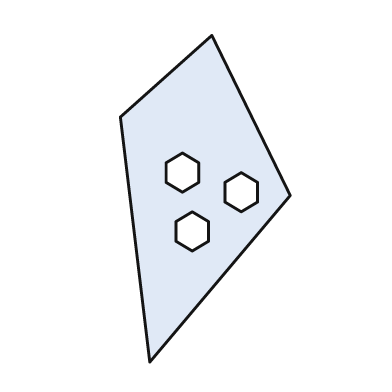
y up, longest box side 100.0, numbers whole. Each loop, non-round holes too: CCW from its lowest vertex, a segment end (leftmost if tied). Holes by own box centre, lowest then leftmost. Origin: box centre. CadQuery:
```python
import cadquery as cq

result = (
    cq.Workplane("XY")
    .moveTo(-17.0, -50.0)
    .lineTo(26.0, 1.0)
    .lineTo(2.0, 50.0)
    .lineTo(-26.0, 25.0)
    .close()
    .moveTo(-4.0, -16.0)
    .lineTo(1.0, -13.0)
    .lineTo(1.0, -7.0)
    .lineTo(-4.0, -4.0)
    .lineTo(-9.0, -7.0)
    .lineTo(-9.0, -13.0)
    .close()
    .moveTo(11.0, -4.0)
    .lineTo(16.0, -1.0)
    .lineTo(16.0, 5.0)
    .lineTo(11.0, 8.0)
    .lineTo(6.0, 5.0)
    .lineTo(6.0, -1.0)
    .close()
    .moveTo(-7.0, 2.0)
    .lineTo(-2.0, 5.0)
    .lineTo(-2.0, 11.0)
    .lineTo(-7.0, 14.0)
    .lineTo(-12.0, 11.0)
    .lineTo(-12.0, 5.0)
    .close()
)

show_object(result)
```